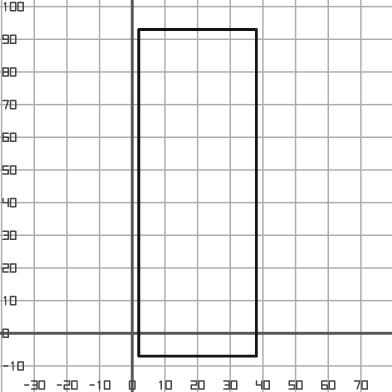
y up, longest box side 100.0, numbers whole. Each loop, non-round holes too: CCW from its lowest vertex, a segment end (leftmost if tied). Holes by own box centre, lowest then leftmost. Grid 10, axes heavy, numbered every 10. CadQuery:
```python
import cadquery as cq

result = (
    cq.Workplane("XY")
    .moveTo(2.0, -7.0)
    .lineTo(38.0, -7.0)
    .lineTo(38.0, 93.0)
    .lineTo(2.0, 93.0)
    .close()
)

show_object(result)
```